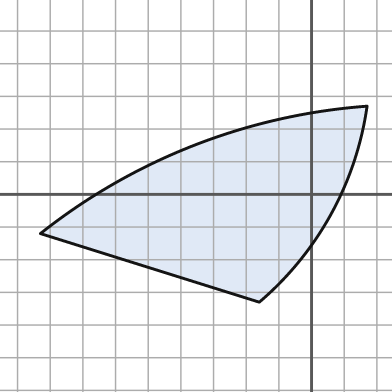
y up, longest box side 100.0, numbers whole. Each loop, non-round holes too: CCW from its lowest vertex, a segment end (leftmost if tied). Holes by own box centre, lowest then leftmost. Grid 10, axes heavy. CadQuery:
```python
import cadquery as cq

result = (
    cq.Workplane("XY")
    .moveTo(-16.0, -33.0)
    .threePointArc((6.0, -6.0), (17.0, 27.0))
    .threePointArc((-36.0, 15.0), (-83.0, -12.0))
    .close()
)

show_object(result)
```